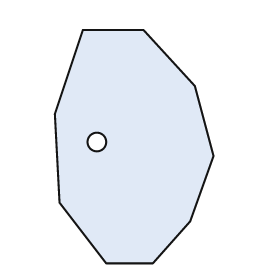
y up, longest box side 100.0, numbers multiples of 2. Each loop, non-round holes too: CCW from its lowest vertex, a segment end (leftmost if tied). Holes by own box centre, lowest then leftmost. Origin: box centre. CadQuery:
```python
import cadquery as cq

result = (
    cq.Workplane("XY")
    .moveTo(-12.0, -50.0)
    .lineTo(8.0, -50.0)
    .lineTo(24.0, -32.0)
    .lineTo(34.0, -4.0)
    .lineTo(26.0, 26.0)
    .lineTo(4.0, 50.0)
    .lineTo(-22.0, 50.0)
    .lineTo(-34.0, 14.0)
    .lineTo(-32.0, -24.0)
    .close()
    .moveTo(-16.0, 2.0)
    .circle(4.0)
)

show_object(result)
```